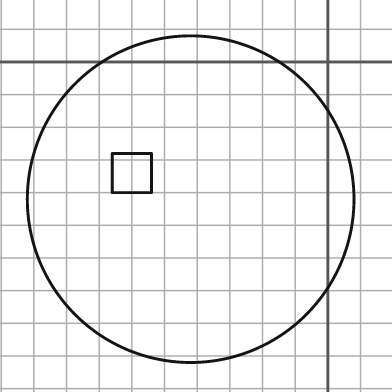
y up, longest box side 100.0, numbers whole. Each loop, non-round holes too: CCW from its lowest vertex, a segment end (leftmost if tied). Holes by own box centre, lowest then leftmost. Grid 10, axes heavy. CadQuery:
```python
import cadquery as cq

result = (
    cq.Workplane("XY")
    .moveTo(-42.0, -42.0)
    .circle(50.0)
    .moveTo(-66.0, -40.0)
    .lineTo(-54.0, -40.0)
    .lineTo(-54.0, -28.0)
    .lineTo(-66.0, -28.0)
    .close()
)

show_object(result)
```